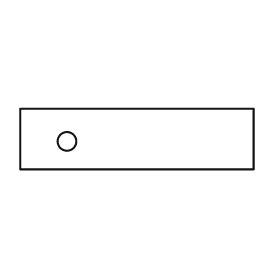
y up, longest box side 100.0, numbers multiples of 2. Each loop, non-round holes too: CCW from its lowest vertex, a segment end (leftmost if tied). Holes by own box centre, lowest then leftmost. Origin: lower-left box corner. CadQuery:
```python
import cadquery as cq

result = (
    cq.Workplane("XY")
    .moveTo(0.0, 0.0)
    .lineTo(100.0, 0.0)
    .lineTo(100.0, 26.0)
    .lineTo(0.0, 26.0)
    .close()
    .moveTo(20.0, 12.0)
    .circle(4.0)
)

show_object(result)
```